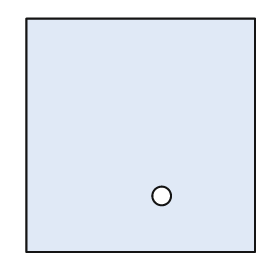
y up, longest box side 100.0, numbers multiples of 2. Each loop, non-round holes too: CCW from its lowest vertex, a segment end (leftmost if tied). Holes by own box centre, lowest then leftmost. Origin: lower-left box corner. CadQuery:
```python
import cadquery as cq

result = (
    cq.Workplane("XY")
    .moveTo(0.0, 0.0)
    .lineTo(98.0, 0.0)
    .lineTo(98.0, 100.0)
    .lineTo(0.0, 100.0)
    .close()
    .moveTo(58.0, 24.0)
    .circle(4.0)
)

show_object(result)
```